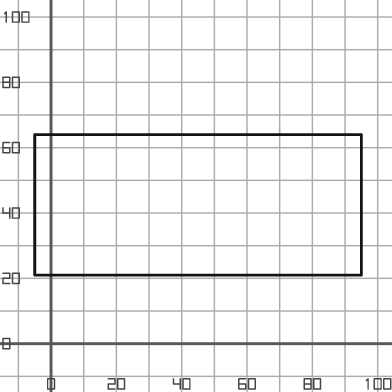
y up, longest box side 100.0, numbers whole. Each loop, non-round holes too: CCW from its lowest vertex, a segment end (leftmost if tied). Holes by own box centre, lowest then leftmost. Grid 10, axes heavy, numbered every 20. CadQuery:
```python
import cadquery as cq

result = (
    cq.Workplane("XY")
    .moveTo(-5.0, 21.0)
    .lineTo(95.0, 21.0)
    .lineTo(95.0, 64.0)
    .lineTo(-5.0, 64.0)
    .close()
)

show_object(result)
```